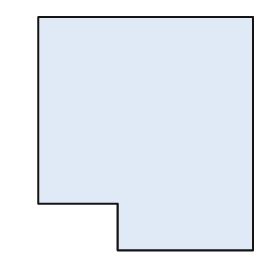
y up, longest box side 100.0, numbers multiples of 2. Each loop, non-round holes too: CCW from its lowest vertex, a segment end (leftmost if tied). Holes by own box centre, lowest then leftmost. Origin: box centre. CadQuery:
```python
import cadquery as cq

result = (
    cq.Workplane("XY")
    .moveTo(-12.0, -50.0)
    .lineTo(46.0, -50.0)
    .lineTo(46.0, 50.0)
    .lineTo(-46.0, 50.0)
    .lineTo(-46.0, -30.0)
    .lineTo(-12.0, -30.0)
    .close()
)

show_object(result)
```